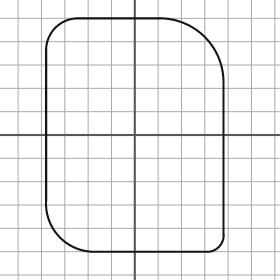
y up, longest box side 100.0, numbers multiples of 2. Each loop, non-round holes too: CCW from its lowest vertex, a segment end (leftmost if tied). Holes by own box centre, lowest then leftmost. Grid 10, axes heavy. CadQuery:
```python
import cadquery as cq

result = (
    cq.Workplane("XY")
    .moveTo(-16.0, -50.0)
    .lineTo(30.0, -50.0)
    .threePointArc((36.0, -48.0), (38.0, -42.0))
    .lineTo(38.0, 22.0)
    .threePointArc((30.0, 42.0), (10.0, 50.0))
    .lineTo(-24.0, 50.0)
    .threePointArc((-34.0, 46.0), (-38.0, 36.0))
    .lineTo(-38.0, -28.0)
    .threePointArc((-32.0, -44.0), (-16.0, -50.0))
    .close()
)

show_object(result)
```